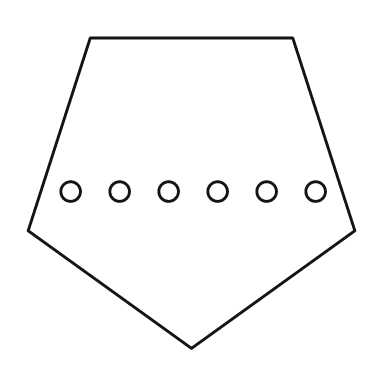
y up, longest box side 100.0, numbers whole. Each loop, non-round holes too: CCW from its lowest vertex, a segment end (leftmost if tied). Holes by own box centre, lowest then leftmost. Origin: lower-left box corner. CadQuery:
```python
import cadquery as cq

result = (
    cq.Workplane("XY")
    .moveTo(50.0, 0.0)
    .lineTo(100.0, 36.0)
    .lineTo(81.0, 95.0)
    .lineTo(19.0, 95.0)
    .lineTo(0.0, 36.0)
    .close()
    .moveTo(13.0, 48.0)
    .circle(3.0)
    .moveTo(28.0, 48.0)
    .circle(3.0)
    .moveTo(43.0, 48.0)
    .circle(3.0)
    .moveTo(58.0, 48.0)
    .circle(3.0)
    .moveTo(73.0, 48.0)
    .circle(3.0)
    .moveTo(88.0, 48.0)
    .circle(3.0)
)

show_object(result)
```